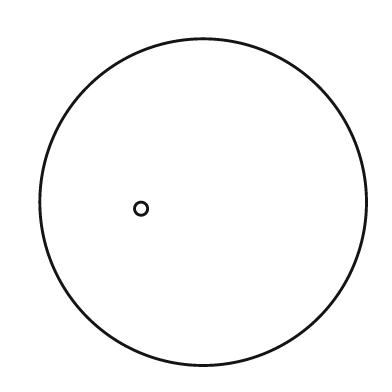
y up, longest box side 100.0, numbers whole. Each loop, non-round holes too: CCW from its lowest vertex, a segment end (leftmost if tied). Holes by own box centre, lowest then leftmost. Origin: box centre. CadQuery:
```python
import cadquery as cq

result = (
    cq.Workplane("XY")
    .moveTo(0.0, 0.0)
    .circle(50.0)
    .moveTo(-19.0, -2.0)
    .circle(2.0)
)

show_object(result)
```